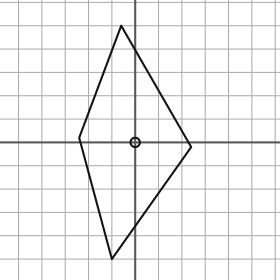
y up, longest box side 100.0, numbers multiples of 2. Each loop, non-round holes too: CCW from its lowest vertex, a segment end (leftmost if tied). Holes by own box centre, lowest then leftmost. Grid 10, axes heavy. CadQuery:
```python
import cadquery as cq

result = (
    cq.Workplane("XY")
    .moveTo(-10.0, -50.0)
    .lineTo(24.0, -2.0)
    .lineTo(-6.0, 50.0)
    .lineTo(-24.0, 2.0)
    .close()
    .moveTo(0.0, 0.0)
    .circle(2.0)
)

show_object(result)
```